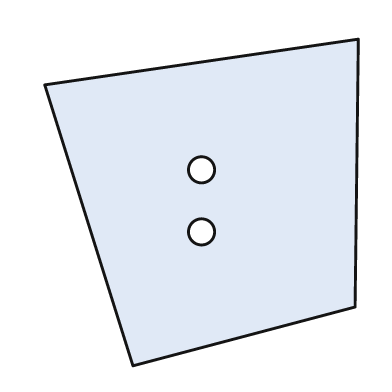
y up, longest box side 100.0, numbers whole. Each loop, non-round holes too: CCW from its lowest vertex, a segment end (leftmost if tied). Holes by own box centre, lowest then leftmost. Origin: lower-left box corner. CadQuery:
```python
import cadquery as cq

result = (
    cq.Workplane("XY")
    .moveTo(27.0, 0.0)
    .lineTo(95.0, 18.0)
    .lineTo(96.0, 100.0)
    .lineTo(0.0, 86.0)
    .close()
    .moveTo(48.0, 41.0)
    .circle(4.0)
    .moveTo(48.0, 60.0)
    .circle(4.0)
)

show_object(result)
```